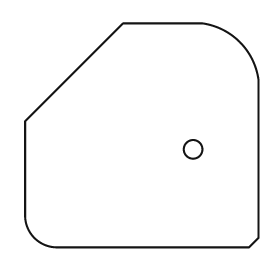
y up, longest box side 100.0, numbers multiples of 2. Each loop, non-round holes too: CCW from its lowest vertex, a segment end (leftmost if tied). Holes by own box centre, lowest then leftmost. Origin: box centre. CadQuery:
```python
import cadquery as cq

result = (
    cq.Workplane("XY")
    .moveTo(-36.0, -48.0)
    .lineTo(46.0, -48.0)
    .lineTo(50.0, -44.0)
    .lineTo(50.0, 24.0)
    .threePointArc((42.0, 40.0), (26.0, 48.0))
    .lineTo(-8.0, 48.0)
    .lineTo(-50.0, 6.0)
    .lineTo(-50.0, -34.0)
    .threePointArc((-46.0, -44.0), (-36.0, -48.0))
    .close()
    .moveTo(22.0, -6.0)
    .circle(4.0)
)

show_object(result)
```